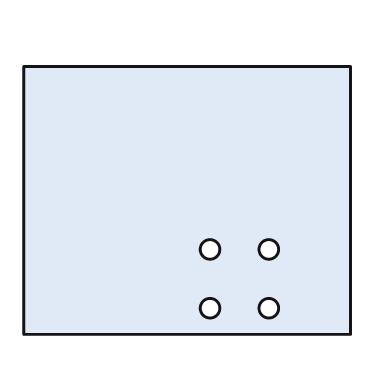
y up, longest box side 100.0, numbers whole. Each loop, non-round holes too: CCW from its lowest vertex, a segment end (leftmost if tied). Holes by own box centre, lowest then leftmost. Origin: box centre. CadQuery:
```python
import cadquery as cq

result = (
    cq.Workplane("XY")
    .moveTo(-50.0, -41.0)
    .lineTo(50.0, -41.0)
    .lineTo(50.0, 41.0)
    .lineTo(-50.0, 41.0)
    .close()
    .moveTo(7.0, -33.0)
    .circle(3.0)
    .moveTo(25.0, -33.0)
    .circle(3.0)
    .moveTo(7.0, -15.0)
    .circle(3.0)
    .moveTo(25.0, -15.0)
    .circle(3.0)
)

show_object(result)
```